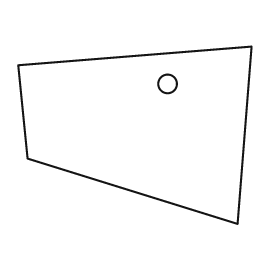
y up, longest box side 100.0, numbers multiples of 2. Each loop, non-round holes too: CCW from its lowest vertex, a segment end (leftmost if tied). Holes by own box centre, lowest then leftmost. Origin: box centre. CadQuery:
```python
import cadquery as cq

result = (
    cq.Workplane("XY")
    .moveTo(44.0, -38.0)
    .lineTo(50.0, 38.0)
    .lineTo(-50.0, 30.0)
    .lineTo(-46.0, -10.0)
    .close()
    .moveTo(14.0, 22.0)
    .circle(4.0)
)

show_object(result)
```